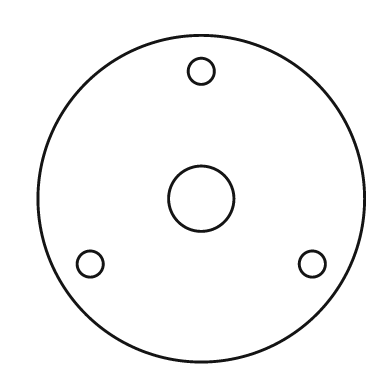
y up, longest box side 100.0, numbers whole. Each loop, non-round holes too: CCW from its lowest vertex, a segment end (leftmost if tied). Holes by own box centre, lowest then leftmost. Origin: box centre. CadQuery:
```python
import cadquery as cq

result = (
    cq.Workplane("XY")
    .moveTo(0.0, 0.0)
    .circle(50.0)
    .moveTo(-34.0, -20.0)
    .circle(4.0)
    .moveTo(34.0, -20.0)
    .circle(4.0)
    .moveTo(0.0, 0.0)
    .circle(10.0)
    .moveTo(0.0, 39.0)
    .circle(4.0)
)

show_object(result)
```